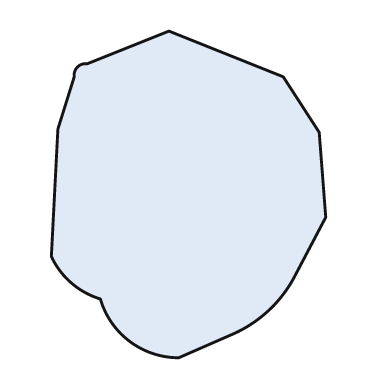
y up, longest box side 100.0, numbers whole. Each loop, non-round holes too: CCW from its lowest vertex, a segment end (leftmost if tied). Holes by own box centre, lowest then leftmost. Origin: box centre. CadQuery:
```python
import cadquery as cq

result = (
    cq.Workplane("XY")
    .moveTo(-3.0, -50.0)
    .lineTo(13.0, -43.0)
    .threePointArc((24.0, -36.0), (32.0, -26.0))
    .lineTo(42.0, -7.0)
    .lineTo(40.0, 19.0)
    .lineTo(29.0, 36.0)
    .lineTo(-6.0, 50.0)
    .lineTo(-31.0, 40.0)
    .threePointArc((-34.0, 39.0), (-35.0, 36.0))
    .lineTo(-40.0, 20.0)
    .lineTo(-42.0, -19.0)
    .threePointArc((-36.0, -27.0), (-27.0, -32.0))
    .threePointArc((-18.0, -45.0), (-3.0, -50.0))
    .close()
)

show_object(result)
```